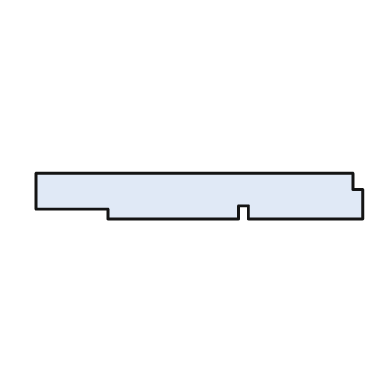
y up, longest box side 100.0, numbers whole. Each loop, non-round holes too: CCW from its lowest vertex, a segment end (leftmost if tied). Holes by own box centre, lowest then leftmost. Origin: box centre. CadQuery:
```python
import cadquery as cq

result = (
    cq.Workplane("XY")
    .moveTo(-28.0, -7.0)
    .lineTo(12.0, -7.0)
    .lineTo(12.0, -3.0)
    .lineTo(15.0, -3.0)
    .lineTo(15.0, -7.0)
    .lineTo(50.0, -7.0)
    .lineTo(50.0, 2.0)
    .lineTo(47.0, 2.0)
    .lineTo(47.0, 7.0)
    .lineTo(-50.0, 7.0)
    .lineTo(-50.0, -4.0)
    .lineTo(-28.0, -4.0)
    .close()
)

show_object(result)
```